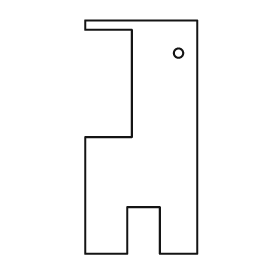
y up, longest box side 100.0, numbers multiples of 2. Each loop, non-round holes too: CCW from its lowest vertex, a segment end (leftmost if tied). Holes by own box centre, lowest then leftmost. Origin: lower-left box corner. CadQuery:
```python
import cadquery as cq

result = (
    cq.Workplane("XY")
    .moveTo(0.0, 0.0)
    .lineTo(18.0, 0.0)
    .lineTo(18.0, 20.0)
    .lineTo(32.0, 20.0)
    .lineTo(32.0, 0.0)
    .lineTo(48.0, 0.0)
    .lineTo(48.0, 100.0)
    .lineTo(0.0, 100.0)
    .lineTo(0.0, 96.0)
    .lineTo(20.0, 96.0)
    .lineTo(20.0, 50.0)
    .lineTo(0.0, 50.0)
    .close()
    .moveTo(40.0, 86.0)
    .circle(2.0)
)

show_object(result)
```